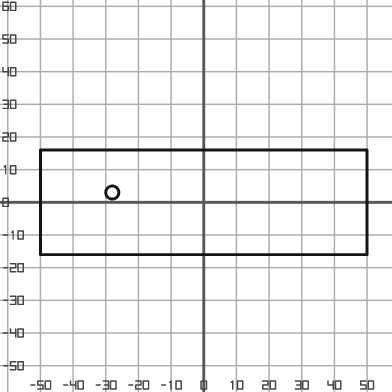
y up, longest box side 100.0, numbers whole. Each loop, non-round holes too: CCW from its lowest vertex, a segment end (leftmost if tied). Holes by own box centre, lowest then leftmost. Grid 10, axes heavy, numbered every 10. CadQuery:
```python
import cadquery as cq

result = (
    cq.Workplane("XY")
    .moveTo(-50.0, -16.0)
    .lineTo(50.0, -16.0)
    .lineTo(50.0, 16.0)
    .lineTo(-50.0, 16.0)
    .close()
    .moveTo(-28.0, 3.0)
    .circle(2.0)
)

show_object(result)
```